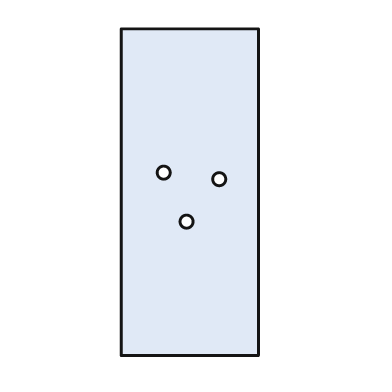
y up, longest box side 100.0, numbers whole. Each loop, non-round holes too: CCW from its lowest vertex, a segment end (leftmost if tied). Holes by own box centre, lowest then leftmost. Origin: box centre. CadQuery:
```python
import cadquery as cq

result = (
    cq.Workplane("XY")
    .moveTo(-21.0, -50.0)
    .lineTo(21.0, -50.0)
    .lineTo(21.0, 50.0)
    .lineTo(-21.0, 50.0)
    .close()
    .moveTo(-1.0, -9.0)
    .circle(2.0)
    .moveTo(9.0, 4.0)
    .circle(2.0)
    .moveTo(-8.0, 6.0)
    .circle(2.0)
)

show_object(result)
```